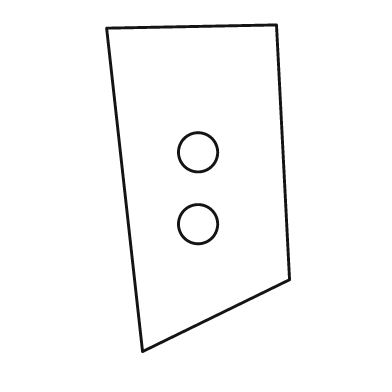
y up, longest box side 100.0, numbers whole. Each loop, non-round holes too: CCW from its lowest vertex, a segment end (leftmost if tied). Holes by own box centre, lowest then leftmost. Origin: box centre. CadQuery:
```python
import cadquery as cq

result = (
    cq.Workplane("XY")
    .moveTo(-17.0, -50.0)
    .lineTo(28.0, -28.0)
    .lineTo(24.0, 50.0)
    .lineTo(-28.0, 49.0)
    .close()
    .moveTo(0.0, -11.0)
    .circle(6.0)
    .moveTo(0.0, 11.0)
    .circle(6.0)
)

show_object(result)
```